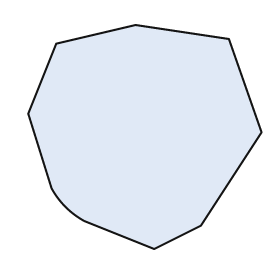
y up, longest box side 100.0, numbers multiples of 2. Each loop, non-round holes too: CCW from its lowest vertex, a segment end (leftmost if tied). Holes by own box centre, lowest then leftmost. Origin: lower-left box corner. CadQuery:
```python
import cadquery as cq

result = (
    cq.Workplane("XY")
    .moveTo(54.0, 0.0)
    .lineTo(74.0, 10.0)
    .lineTo(100.0, 50.0)
    .lineTo(86.0, 90.0)
    .lineTo(46.0, 96.0)
    .lineTo(12.0, 88.0)
    .lineTo(0.0, 58.0)
    .lineTo(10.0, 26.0)
    .threePointArc((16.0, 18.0), (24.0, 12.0))
    .close()
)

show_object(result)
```